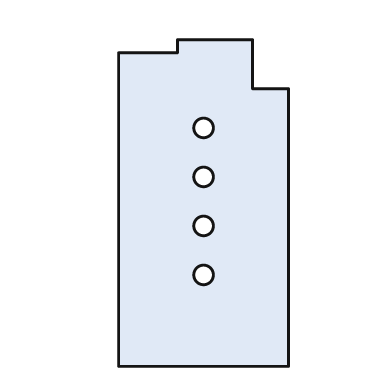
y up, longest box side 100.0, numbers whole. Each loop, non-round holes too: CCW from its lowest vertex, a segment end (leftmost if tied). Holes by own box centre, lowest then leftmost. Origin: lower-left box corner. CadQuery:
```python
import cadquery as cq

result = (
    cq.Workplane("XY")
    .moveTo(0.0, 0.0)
    .lineTo(52.0, 0.0)
    .lineTo(52.0, 85.0)
    .lineTo(41.0, 85.0)
    .lineTo(41.0, 100.0)
    .lineTo(18.0, 100.0)
    .lineTo(18.0, 96.0)
    .lineTo(0.0, 96.0)
    .close()
    .moveTo(26.0, 28.0)
    .circle(3.0)
    .moveTo(26.0, 43.0)
    .circle(3.0)
    .moveTo(26.0, 58.0)
    .circle(3.0)
    .moveTo(26.0, 73.0)
    .circle(3.0)
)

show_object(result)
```